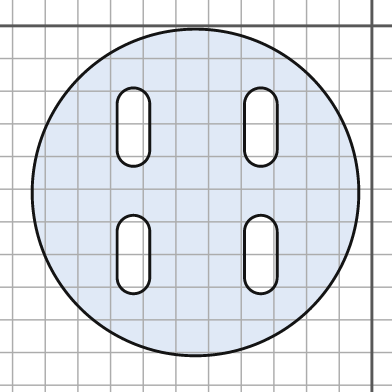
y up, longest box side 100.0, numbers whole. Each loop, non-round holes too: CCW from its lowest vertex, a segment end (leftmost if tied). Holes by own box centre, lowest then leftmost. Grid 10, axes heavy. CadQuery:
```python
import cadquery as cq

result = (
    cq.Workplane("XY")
    .moveTo(-54.0, -51.0)
    .circle(50.0)
    .moveTo(-78.0, -77.0)
    .threePointArc((-73.0, -82.0), (-68.0, -77.0))
    .lineTo(-68.0, -63.0)
    .threePointArc((-73.0, -58.0), (-78.0, -63.0))
    .close()
    .moveTo(-39.0, -77.0)
    .threePointArc((-34.0, -82.0), (-29.0, -77.0))
    .lineTo(-29.0, -63.0)
    .threePointArc((-34.0, -58.0), (-39.0, -63.0))
    .close()
    .moveTo(-78.0, -38.0)
    .threePointArc((-73.0, -43.0), (-68.0, -38.0))
    .lineTo(-68.0, -24.0)
    .threePointArc((-73.0, -19.0), (-78.0, -24.0))
    .close()
    .moveTo(-39.0, -38.0)
    .threePointArc((-34.0, -43.0), (-29.0, -38.0))
    .lineTo(-29.0, -24.0)
    .threePointArc((-34.0, -19.0), (-39.0, -24.0))
    .close()
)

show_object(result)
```